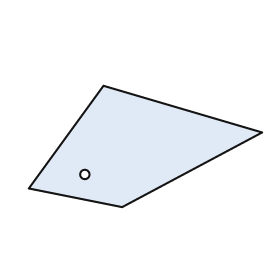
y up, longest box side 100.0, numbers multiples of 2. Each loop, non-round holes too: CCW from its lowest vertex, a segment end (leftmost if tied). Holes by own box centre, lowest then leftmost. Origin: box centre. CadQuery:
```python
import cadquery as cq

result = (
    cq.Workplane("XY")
    .moveTo(-10.0, -26.0)
    .lineTo(50.0, 6.0)
    .lineTo(-18.0, 26.0)
    .lineTo(-50.0, -18.0)
    .close()
    .moveTo(-26.0, -12.0)
    .circle(2.0)
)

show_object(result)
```